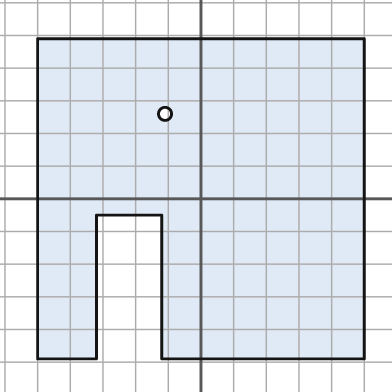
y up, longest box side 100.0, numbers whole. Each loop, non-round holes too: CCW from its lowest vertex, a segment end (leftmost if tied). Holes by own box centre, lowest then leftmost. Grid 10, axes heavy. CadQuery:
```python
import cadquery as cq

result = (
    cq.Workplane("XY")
    .moveTo(-50.0, -49.0)
    .lineTo(-32.0, -49.0)
    .lineTo(-32.0, -5.0)
    .lineTo(-12.0, -5.0)
    .lineTo(-12.0, -49.0)
    .lineTo(50.0, -49.0)
    .lineTo(50.0, 49.0)
    .lineTo(-50.0, 49.0)
    .close()
    .moveTo(-11.0, 26.0)
    .circle(2.0)
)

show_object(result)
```